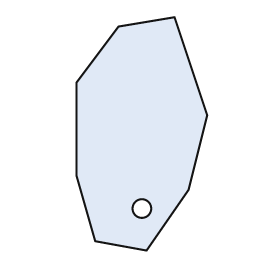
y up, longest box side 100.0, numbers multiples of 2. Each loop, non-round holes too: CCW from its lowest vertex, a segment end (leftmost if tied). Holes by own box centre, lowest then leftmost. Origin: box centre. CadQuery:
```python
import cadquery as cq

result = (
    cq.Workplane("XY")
    .moveTo(2.0, -50.0)
    .lineTo(20.0, -24.0)
    .lineTo(28.0, 8.0)
    .lineTo(14.0, 50.0)
    .lineTo(-10.0, 46.0)
    .lineTo(-28.0, 22.0)
    .lineTo(-28.0, -18.0)
    .lineTo(-20.0, -46.0)
    .close()
    .moveTo(0.0, -32.0)
    .circle(4.0)
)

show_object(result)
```